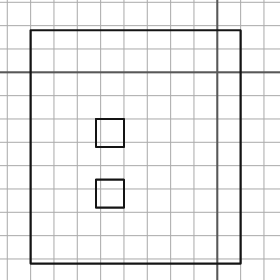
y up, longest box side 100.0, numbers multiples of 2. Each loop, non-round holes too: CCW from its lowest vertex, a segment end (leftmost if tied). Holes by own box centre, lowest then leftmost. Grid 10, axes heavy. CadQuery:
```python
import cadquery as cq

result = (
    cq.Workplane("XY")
    .moveTo(-80.0, -82.0)
    .lineTo(10.0, -82.0)
    .lineTo(10.0, 18.0)
    .lineTo(-80.0, 18.0)
    .close()
    .moveTo(-52.0, -58.0)
    .lineTo(-40.0, -58.0)
    .lineTo(-40.0, -46.0)
    .lineTo(-52.0, -46.0)
    .close()
    .moveTo(-52.0, -32.0)
    .lineTo(-40.0, -32.0)
    .lineTo(-40.0, -20.0)
    .lineTo(-52.0, -20.0)
    .close()
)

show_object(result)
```